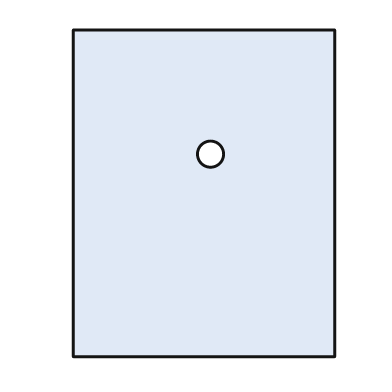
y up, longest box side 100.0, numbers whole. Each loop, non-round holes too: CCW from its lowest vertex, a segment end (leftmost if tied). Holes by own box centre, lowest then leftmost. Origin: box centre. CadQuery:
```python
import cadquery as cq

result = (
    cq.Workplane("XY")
    .moveTo(-40.0, -50.0)
    .lineTo(40.0, -50.0)
    .lineTo(40.0, 50.0)
    .lineTo(-40.0, 50.0)
    .close()
    .moveTo(2.0, 12.0)
    .circle(4.0)
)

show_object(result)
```